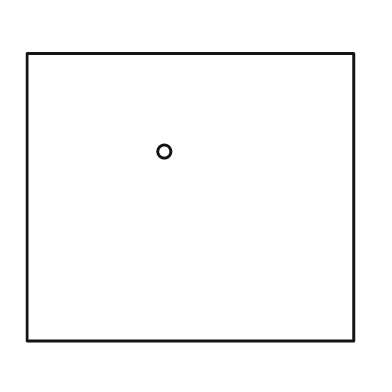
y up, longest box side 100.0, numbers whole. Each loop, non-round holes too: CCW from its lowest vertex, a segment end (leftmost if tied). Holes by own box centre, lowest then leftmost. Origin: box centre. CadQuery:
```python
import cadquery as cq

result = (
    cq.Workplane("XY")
    .moveTo(-50.0, -44.0)
    .lineTo(50.0, -44.0)
    .lineTo(50.0, 44.0)
    .lineTo(-50.0, 44.0)
    .close()
    .moveTo(-8.0, 14.0)
    .circle(2.0)
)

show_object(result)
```